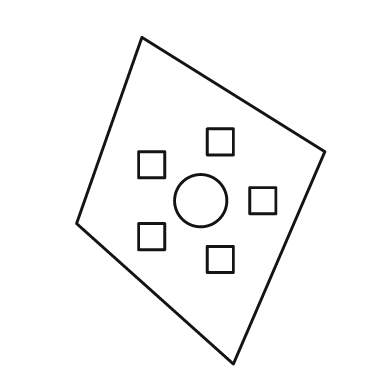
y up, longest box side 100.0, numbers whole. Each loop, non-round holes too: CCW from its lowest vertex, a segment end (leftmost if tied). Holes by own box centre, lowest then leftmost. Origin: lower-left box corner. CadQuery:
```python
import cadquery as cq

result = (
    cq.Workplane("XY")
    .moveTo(48.0, 0.0)
    .lineTo(76.0, 65.0)
    .lineTo(20.0, 100.0)
    .lineTo(0.0, 43.0)
    .close()
    .moveTo(40.0, 28.0)
    .lineTo(48.0, 28.0)
    .lineTo(48.0, 36.0)
    .lineTo(40.0, 36.0)
    .close()
    .moveTo(19.0, 35.0)
    .lineTo(27.0, 35.0)
    .lineTo(27.0, 43.0)
    .lineTo(19.0, 43.0)
    .close()
    .moveTo(38.0, 50.0)
    .circle(8.0)
    .moveTo(53.0, 46.0)
    .lineTo(61.0, 46.0)
    .lineTo(61.0, 54.0)
    .lineTo(53.0, 54.0)
    .close()
    .moveTo(19.0, 57.0)
    .lineTo(27.0, 57.0)
    .lineTo(27.0, 65.0)
    .lineTo(19.0, 65.0)
    .close()
    .moveTo(40.0, 64.0)
    .lineTo(48.0, 64.0)
    .lineTo(48.0, 72.0)
    .lineTo(40.0, 72.0)
    .close()
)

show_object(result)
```